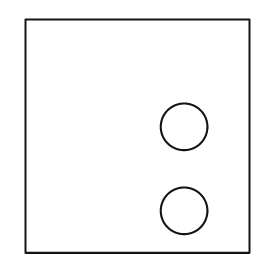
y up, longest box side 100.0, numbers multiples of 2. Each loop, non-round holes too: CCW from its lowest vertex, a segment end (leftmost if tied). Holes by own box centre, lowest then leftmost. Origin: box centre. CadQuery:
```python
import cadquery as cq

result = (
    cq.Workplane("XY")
    .moveTo(-48.0, -50.0)
    .lineTo(48.0, -50.0)
    .lineTo(48.0, 50.0)
    .lineTo(-48.0, 50.0)
    .close()
    .moveTo(20.0, -32.0)
    .circle(10.0)
    .moveTo(20.0, 4.0)
    .circle(10.0)
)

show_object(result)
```